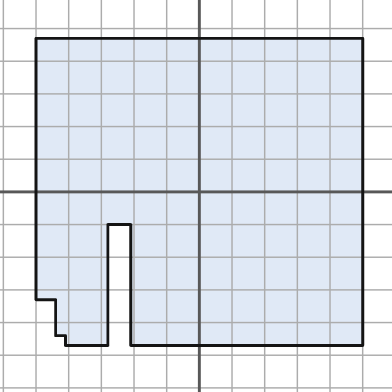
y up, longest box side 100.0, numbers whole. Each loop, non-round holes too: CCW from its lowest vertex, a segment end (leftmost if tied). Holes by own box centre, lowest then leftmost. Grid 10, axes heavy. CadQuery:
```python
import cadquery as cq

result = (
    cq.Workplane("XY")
    .moveTo(-41.0, -47.0)
    .lineTo(-28.0, -47.0)
    .lineTo(-28.0, -10.0)
    .lineTo(-21.0, -10.0)
    .lineTo(-21.0, -47.0)
    .lineTo(50.0, -47.0)
    .lineTo(50.0, 47.0)
    .lineTo(-50.0, 47.0)
    .lineTo(-50.0, -33.0)
    .lineTo(-44.0, -33.0)
    .lineTo(-44.0, -44.0)
    .lineTo(-41.0, -44.0)
    .close()
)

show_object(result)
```